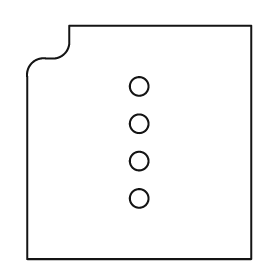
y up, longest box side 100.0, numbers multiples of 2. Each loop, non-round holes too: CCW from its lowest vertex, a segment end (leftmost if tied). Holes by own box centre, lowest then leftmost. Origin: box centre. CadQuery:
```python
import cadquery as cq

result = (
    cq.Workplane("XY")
    .moveTo(-48.0, -50.0)
    .lineTo(48.0, -50.0)
    .lineTo(48.0, 50.0)
    .lineTo(-30.0, 50.0)
    .lineTo(-30.0, 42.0)
    .threePointArc((-32.0, 38.0), (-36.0, 36.0))
    .lineTo(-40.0, 36.0)
    .threePointArc((-46.0, 34.0), (-48.0, 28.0))
    .close()
    .moveTo(0.0, -24.0)
    .circle(4.0)
    .moveTo(0.0, -8.0)
    .circle(4.0)
    .moveTo(0.0, 8.0)
    .circle(4.0)
    .moveTo(0.0, 24.0)
    .circle(4.0)
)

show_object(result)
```